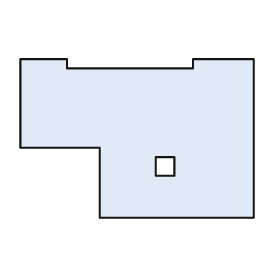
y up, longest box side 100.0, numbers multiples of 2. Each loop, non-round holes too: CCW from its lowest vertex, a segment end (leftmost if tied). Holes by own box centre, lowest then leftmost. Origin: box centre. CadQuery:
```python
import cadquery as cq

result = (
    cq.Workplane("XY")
    .moveTo(-16.0, -34.0)
    .lineTo(50.0, -34.0)
    .lineTo(50.0, 34.0)
    .lineTo(24.0, 34.0)
    .lineTo(24.0, 30.0)
    .lineTo(-30.0, 30.0)
    .lineTo(-30.0, 34.0)
    .lineTo(-50.0, 34.0)
    .lineTo(-50.0, -4.0)
    .lineTo(-16.0, -4.0)
    .close()
    .moveTo(8.0, -16.0)
    .lineTo(16.0, -16.0)
    .lineTo(16.0, -8.0)
    .lineTo(8.0, -8.0)
    .close()
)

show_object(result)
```